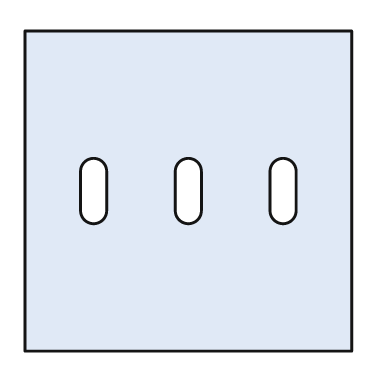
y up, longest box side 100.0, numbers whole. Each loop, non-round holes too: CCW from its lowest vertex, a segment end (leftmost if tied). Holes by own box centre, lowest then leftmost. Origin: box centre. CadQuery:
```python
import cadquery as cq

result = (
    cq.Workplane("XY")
    .moveTo(-50.0, -49.0)
    .lineTo(50.0, -49.0)
    .lineTo(50.0, 49.0)
    .lineTo(-50.0, 49.0)
    .close()
    .moveTo(-33.0, -6.0)
    .threePointArc((-29.0, -10.0), (-25.0, -6.0))
    .lineTo(-25.0, 6.0)
    .threePointArc((-29.0, 10.0), (-33.0, 6.0))
    .close()
    .moveTo(-4.0, -6.0)
    .threePointArc((0.0, -10.0), (4.0, -6.0))
    .lineTo(4.0, 6.0)
    .threePointArc((0.0, 10.0), (-4.0, 6.0))
    .close()
    .moveTo(25.0, -6.0)
    .threePointArc((29.0, -10.0), (33.0, -6.0))
    .lineTo(33.0, 6.0)
    .threePointArc((29.0, 10.0), (25.0, 6.0))
    .close()
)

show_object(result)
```